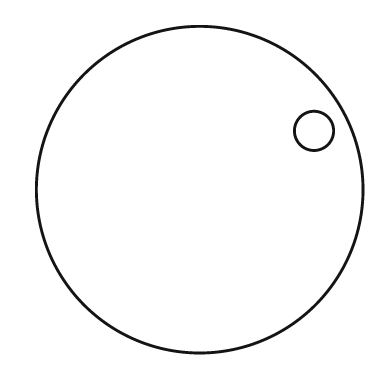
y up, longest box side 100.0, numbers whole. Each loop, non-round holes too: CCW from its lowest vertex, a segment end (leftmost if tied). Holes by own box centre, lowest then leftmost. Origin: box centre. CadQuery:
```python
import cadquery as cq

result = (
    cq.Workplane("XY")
    .moveTo(0.0, 0.0)
    .circle(50.0)
    .moveTo(35.0, 18.0)
    .circle(6.0)
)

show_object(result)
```